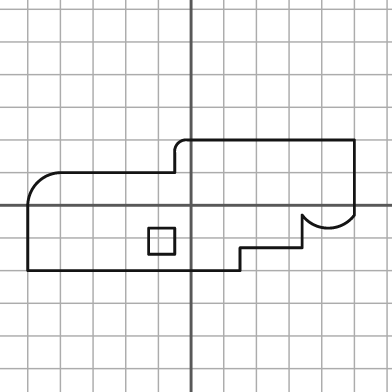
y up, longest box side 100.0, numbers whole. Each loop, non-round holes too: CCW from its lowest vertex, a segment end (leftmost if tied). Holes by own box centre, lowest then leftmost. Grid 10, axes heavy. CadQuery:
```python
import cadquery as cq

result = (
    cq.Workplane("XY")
    .moveTo(-50.0, -20.0)
    .lineTo(15.0, -20.0)
    .lineTo(15.0, -13.0)
    .lineTo(34.0, -13.0)
    .lineTo(34.0, -3.0)
    .threePointArc((42.0, -7.0), (50.0, -3.0))
    .lineTo(50.0, 20.0)
    .lineTo(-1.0, 20.0)
    .threePointArc((-4.0, 19.0), (-5.0, 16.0))
    .lineTo(-5.0, 10.0)
    .lineTo(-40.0, 10.0)
    .threePointArc((-47.0, 7.0), (-50.0, 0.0))
    .close()
    .moveTo(-13.0, -15.0)
    .lineTo(-5.0, -15.0)
    .lineTo(-5.0, -7.0)
    .lineTo(-13.0, -7.0)
    .close()
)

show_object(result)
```